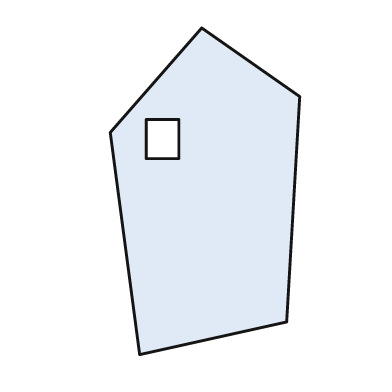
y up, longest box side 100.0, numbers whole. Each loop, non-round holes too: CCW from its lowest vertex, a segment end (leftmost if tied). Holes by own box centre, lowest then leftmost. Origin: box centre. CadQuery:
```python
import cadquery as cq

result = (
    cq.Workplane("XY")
    .moveTo(-20.0, -50.0)
    .lineTo(25.0, -40.0)
    .lineTo(29.0, 29.0)
    .lineTo(-1.0, 50.0)
    .lineTo(-29.0, 18.0)
    .close()
    .moveTo(-18.0, 10.0)
    .lineTo(-8.0, 10.0)
    .lineTo(-8.0, 22.0)
    .lineTo(-18.0, 22.0)
    .close()
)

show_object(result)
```